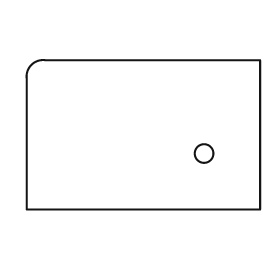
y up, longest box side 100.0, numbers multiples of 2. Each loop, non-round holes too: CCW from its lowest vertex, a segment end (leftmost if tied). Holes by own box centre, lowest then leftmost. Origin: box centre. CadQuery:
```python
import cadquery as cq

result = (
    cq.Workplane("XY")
    .moveTo(-50.0, -32.0)
    .lineTo(50.0, -32.0)
    .lineTo(50.0, 32.0)
    .lineTo(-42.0, 32.0)
    .threePointArc((-48.0, 30.0), (-50.0, 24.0))
    .close()
    .moveTo(26.0, -8.0)
    .circle(4.0)
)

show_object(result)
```